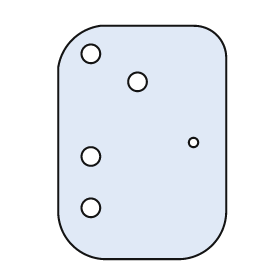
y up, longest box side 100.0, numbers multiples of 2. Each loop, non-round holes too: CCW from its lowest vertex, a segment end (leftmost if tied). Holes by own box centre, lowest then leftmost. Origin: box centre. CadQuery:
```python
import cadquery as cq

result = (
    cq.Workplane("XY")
    .moveTo(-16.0, -50.0)
    .lineTo(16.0, -50.0)
    .threePointArc((30.0, -44.0), (36.0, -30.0))
    .lineTo(36.0, 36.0)
    .threePointArc((32.0, 46.0), (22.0, 50.0))
    .lineTo(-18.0, 50.0)
    .threePointArc((-30.0, 44.0), (-36.0, 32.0))
    .lineTo(-36.0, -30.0)
    .threePointArc((-30.0, -44.0), (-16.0, -50.0))
    .close()
    .moveTo(-22.0, -28.0)
    .circle(4.0)
    .moveTo(-22.0, -6.0)
    .circle(4.0)
    .moveTo(22.0, 0.0)
    .circle(2.0)
    .moveTo(-2.0, 26.0)
    .circle(4.0)
    .moveTo(-22.0, 38.0)
    .circle(4.0)
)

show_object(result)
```